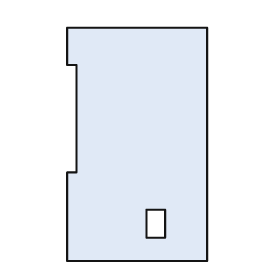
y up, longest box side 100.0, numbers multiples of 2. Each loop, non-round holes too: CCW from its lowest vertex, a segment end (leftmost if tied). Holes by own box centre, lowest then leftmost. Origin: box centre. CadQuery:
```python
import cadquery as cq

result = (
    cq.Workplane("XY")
    .moveTo(-30.0, -50.0)
    .lineTo(30.0, -50.0)
    .lineTo(30.0, 50.0)
    .lineTo(-30.0, 50.0)
    .lineTo(-30.0, 34.0)
    .lineTo(-26.0, 34.0)
    .lineTo(-26.0, -12.0)
    .lineTo(-30.0, -12.0)
    .close()
    .moveTo(4.0, -40.0)
    .lineTo(12.0, -40.0)
    .lineTo(12.0, -28.0)
    .lineTo(4.0, -28.0)
    .close()
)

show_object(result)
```